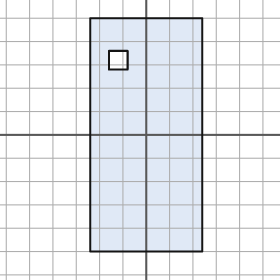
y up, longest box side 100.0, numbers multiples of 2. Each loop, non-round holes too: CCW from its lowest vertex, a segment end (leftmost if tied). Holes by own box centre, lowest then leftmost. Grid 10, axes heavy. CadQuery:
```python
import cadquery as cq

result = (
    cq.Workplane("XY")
    .moveTo(-24.0, -50.0)
    .lineTo(24.0, -50.0)
    .lineTo(24.0, 50.0)
    .lineTo(-24.0, 50.0)
    .close()
    .moveTo(-16.0, 28.0)
    .lineTo(-8.0, 28.0)
    .lineTo(-8.0, 36.0)
    .lineTo(-16.0, 36.0)
    .close()
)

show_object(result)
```